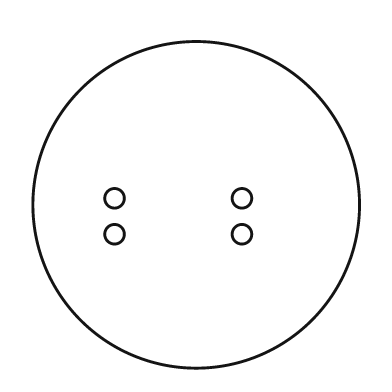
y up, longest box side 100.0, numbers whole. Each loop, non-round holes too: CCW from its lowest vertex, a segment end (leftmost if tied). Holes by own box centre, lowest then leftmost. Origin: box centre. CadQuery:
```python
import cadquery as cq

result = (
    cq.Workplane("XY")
    .moveTo(0.0, 0.0)
    .circle(50.0)
    .moveTo(-25.0, -9.0)
    .circle(3.0)
    .moveTo(14.0, -9.0)
    .circle(3.0)
    .moveTo(-25.0, 2.0)
    .circle(3.0)
    .moveTo(14.0, 2.0)
    .circle(3.0)
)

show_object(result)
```